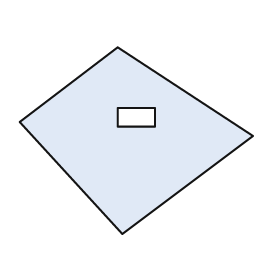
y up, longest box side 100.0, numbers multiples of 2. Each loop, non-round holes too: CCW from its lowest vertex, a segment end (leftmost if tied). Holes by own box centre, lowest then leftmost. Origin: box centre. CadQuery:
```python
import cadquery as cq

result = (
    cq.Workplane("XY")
    .moveTo(-6.0, -40.0)
    .lineTo(50.0, 2.0)
    .lineTo(-8.0, 40.0)
    .lineTo(-50.0, 8.0)
    .close()
    .moveTo(-8.0, 6.0)
    .lineTo(8.0, 6.0)
    .lineTo(8.0, 14.0)
    .lineTo(-8.0, 14.0)
    .close()
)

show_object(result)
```